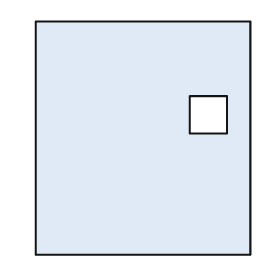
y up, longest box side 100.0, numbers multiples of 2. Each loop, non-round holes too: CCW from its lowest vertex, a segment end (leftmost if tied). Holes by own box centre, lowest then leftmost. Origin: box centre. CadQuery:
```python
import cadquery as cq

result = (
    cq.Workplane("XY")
    .moveTo(-46.0, -50.0)
    .lineTo(46.0, -50.0)
    .lineTo(46.0, 50.0)
    .lineTo(-46.0, 50.0)
    .close()
    .moveTo(20.0, 2.0)
    .lineTo(36.0, 2.0)
    .lineTo(36.0, 18.0)
    .lineTo(20.0, 18.0)
    .close()
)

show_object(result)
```